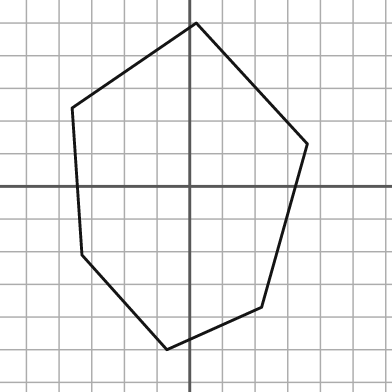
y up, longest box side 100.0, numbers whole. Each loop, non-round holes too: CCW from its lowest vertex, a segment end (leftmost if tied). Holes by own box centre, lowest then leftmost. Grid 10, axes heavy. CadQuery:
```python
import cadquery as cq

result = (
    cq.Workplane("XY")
    .moveTo(-7.0, -50.0)
    .lineTo(22.0, -37.0)
    .lineTo(36.0, 13.0)
    .lineTo(2.0, 50.0)
    .lineTo(-36.0, 24.0)
    .lineTo(-33.0, -21.0)
    .close()
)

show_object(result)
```